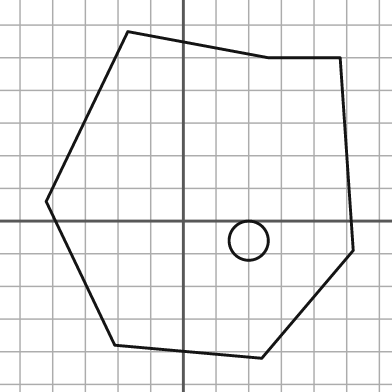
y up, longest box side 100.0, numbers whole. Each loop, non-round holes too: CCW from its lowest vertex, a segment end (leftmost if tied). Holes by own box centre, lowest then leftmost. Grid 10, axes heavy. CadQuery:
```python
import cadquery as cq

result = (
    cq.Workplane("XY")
    .moveTo(24.0, -42.0)
    .lineTo(52.0, -9.0)
    .lineTo(48.0, 50.0)
    .lineTo(26.0, 50.0)
    .lineTo(-17.0, 58.0)
    .lineTo(-42.0, 6.0)
    .lineTo(-21.0, -38.0)
    .close()
    .moveTo(20.0, -6.0)
    .circle(6.0)
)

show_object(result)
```